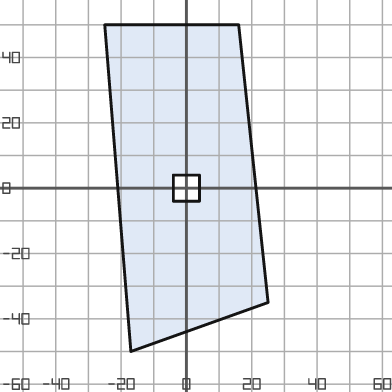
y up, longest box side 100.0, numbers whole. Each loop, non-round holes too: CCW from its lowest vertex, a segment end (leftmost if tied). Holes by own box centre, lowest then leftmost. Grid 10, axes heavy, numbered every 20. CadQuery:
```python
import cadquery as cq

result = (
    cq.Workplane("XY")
    .moveTo(-17.0, -50.0)
    .lineTo(25.0, -35.0)
    .lineTo(16.0, 50.0)
    .lineTo(-25.0, 50.0)
    .close()
    .moveTo(-4.0, -4.0)
    .lineTo(4.0, -4.0)
    .lineTo(4.0, 4.0)
    .lineTo(-4.0, 4.0)
    .close()
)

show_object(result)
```